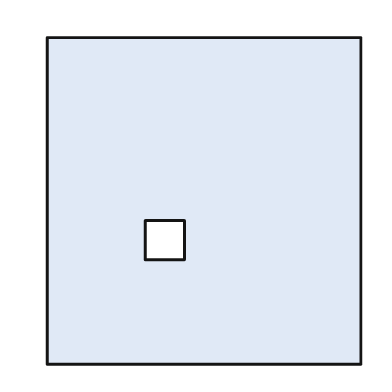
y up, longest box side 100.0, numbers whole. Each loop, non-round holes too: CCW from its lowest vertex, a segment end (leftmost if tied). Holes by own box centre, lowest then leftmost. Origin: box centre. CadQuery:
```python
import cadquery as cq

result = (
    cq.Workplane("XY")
    .moveTo(-48.0, -50.0)
    .lineTo(48.0, -50.0)
    .lineTo(48.0, 50.0)
    .lineTo(-48.0, 50.0)
    .close()
    .moveTo(-18.0, -18.0)
    .lineTo(-6.0, -18.0)
    .lineTo(-6.0, -6.0)
    .lineTo(-18.0, -6.0)
    .close()
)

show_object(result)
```